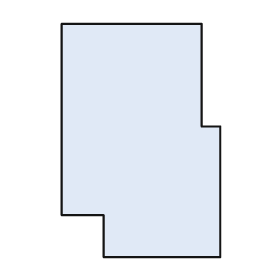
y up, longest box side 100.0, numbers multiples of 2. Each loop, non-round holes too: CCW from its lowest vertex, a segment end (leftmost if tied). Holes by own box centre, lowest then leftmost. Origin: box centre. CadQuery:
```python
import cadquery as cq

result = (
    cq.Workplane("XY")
    .moveTo(-16.0, -50.0)
    .lineTo(34.0, -50.0)
    .lineTo(34.0, 6.0)
    .lineTo(26.0, 6.0)
    .lineTo(26.0, 50.0)
    .lineTo(-34.0, 50.0)
    .lineTo(-34.0, -32.0)
    .lineTo(-16.0, -32.0)
    .close()
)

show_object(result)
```